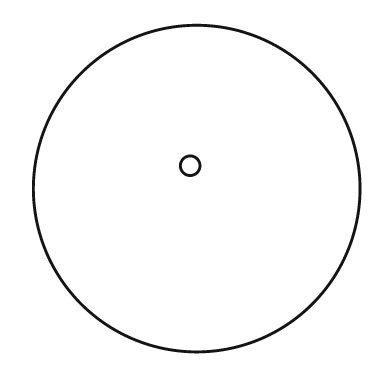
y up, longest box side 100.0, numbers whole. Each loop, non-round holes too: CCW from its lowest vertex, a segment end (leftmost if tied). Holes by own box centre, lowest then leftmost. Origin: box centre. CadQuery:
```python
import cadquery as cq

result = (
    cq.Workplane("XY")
    .moveTo(0.0, 0.0)
    .circle(50.0)
    .moveTo(-2.0, 7.0)
    .circle(3.0)
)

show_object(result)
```